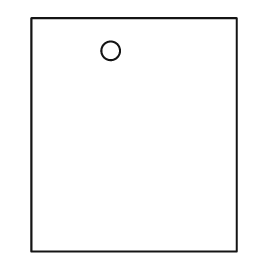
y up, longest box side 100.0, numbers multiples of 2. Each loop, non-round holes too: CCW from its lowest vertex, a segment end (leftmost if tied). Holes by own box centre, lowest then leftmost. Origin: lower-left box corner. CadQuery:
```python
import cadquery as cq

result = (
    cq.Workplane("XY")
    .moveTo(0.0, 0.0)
    .lineTo(88.0, 0.0)
    .lineTo(88.0, 100.0)
    .lineTo(0.0, 100.0)
    .close()
    .moveTo(34.0, 86.0)
    .circle(4.0)
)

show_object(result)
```